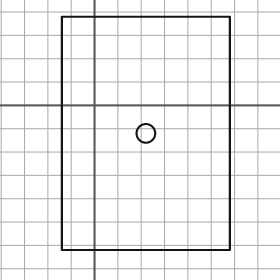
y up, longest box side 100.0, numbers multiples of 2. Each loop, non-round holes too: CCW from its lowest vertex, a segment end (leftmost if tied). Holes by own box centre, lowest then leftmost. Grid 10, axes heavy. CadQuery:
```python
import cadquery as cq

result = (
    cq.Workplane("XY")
    .moveTo(-14.0, -62.0)
    .lineTo(58.0, -62.0)
    .lineTo(58.0, 38.0)
    .lineTo(-14.0, 38.0)
    .close()
    .moveTo(22.0, -12.0)
    .circle(4.0)
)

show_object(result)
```